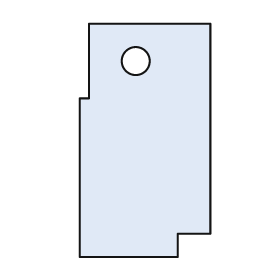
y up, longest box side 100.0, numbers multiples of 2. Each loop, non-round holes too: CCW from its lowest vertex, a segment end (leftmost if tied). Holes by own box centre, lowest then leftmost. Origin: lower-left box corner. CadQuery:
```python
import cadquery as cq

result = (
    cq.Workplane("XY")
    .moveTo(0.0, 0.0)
    .lineTo(42.0, 0.0)
    .lineTo(42.0, 10.0)
    .lineTo(56.0, 10.0)
    .lineTo(56.0, 100.0)
    .lineTo(4.0, 100.0)
    .lineTo(4.0, 68.0)
    .lineTo(0.0, 68.0)
    .close()
    .moveTo(24.0, 84.0)
    .circle(6.0)
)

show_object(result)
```